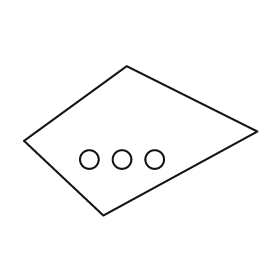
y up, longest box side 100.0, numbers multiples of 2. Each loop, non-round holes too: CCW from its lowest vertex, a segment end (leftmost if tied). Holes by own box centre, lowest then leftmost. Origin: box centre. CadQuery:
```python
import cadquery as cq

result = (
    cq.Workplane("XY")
    .moveTo(-16.0, -32.0)
    .lineTo(50.0, 4.0)
    .lineTo(-6.0, 32.0)
    .lineTo(-50.0, 0.0)
    .close()
    .moveTo(-22.0, -8.0)
    .circle(4.0)
    .moveTo(-8.0, -8.0)
    .circle(4.0)
    .moveTo(6.0, -8.0)
    .circle(4.0)
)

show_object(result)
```